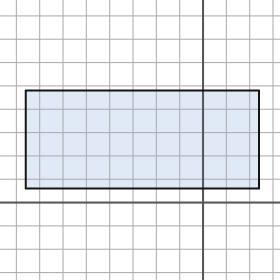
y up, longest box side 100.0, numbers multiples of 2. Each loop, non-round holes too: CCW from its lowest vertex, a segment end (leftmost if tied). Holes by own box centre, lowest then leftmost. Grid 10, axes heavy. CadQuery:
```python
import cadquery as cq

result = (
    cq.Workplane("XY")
    .moveTo(-76.0, 6.0)
    .lineTo(24.0, 6.0)
    .lineTo(24.0, 48.0)
    .lineTo(-76.0, 48.0)
    .close()
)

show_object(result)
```